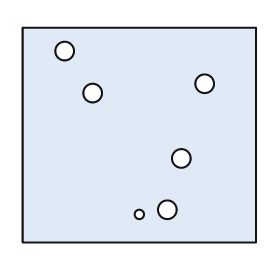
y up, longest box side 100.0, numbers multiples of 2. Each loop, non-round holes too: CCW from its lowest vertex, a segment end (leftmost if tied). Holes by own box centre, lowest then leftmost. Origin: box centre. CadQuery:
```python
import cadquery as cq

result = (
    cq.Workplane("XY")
    .moveTo(-50.0, -46.0)
    .lineTo(50.0, -46.0)
    .lineTo(50.0, 46.0)
    .lineTo(-50.0, 46.0)
    .close()
    .moveTo(0.0, -34.0)
    .circle(2.0)
    .moveTo(12.0, -32.0)
    .circle(4.0)
    .moveTo(18.0, -10.0)
    .circle(4.0)
    .moveTo(-20.0, 18.0)
    .circle(4.0)
    .moveTo(28.0, 22.0)
    .circle(4.0)
    .moveTo(-32.0, 36.0)
    .circle(4.0)
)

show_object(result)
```